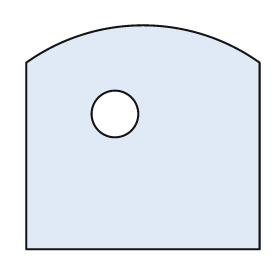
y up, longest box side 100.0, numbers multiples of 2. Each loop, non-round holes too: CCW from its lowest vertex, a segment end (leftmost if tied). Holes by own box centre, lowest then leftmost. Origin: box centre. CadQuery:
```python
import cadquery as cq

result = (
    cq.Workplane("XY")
    .moveTo(-50.0, -48.0)
    .lineTo(50.0, -48.0)
    .lineTo(50.0, 32.0)
    .threePointArc((0.0, 48.0), (-50.0, 32.0))
    .close()
    .moveTo(-12.0, 10.0)
    .circle(10.0)
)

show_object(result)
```